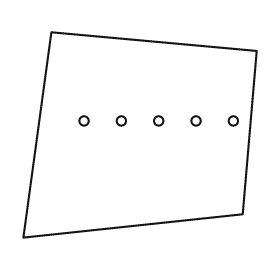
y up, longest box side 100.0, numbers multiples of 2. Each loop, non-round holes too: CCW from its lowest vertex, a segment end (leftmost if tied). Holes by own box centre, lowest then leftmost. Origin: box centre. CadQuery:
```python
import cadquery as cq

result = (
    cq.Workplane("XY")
    .moveTo(-50.0, -44.0)
    .lineTo(44.0, -34.0)
    .lineTo(50.0, 36.0)
    .lineTo(-38.0, 44.0)
    .close()
    .moveTo(-24.0, 6.0)
    .circle(2.0)
    .moveTo(-8.0, 6.0)
    .circle(2.0)
    .moveTo(8.0, 6.0)
    .circle(2.0)
    .moveTo(24.0, 6.0)
    .circle(2.0)
    .moveTo(40.0, 6.0)
    .circle(2.0)
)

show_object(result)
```